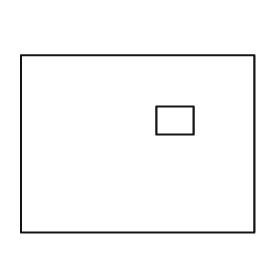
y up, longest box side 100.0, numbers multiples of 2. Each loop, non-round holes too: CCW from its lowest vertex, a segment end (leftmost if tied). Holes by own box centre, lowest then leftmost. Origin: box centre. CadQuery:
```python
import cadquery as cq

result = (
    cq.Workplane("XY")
    .moveTo(-50.0, -38.0)
    .lineTo(50.0, -38.0)
    .lineTo(50.0, 38.0)
    .lineTo(-50.0, 38.0)
    .close()
    .moveTo(8.0, 4.0)
    .lineTo(24.0, 4.0)
    .lineTo(24.0, 16.0)
    .lineTo(8.0, 16.0)
    .close()
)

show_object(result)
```